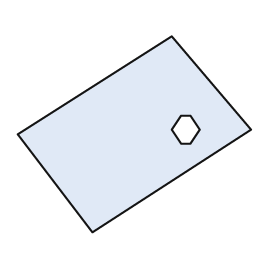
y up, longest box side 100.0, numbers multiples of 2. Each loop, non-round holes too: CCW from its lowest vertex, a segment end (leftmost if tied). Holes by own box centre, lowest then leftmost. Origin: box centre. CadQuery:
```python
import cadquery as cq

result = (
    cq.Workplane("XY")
    .moveTo(-18.0, -42.0)
    .lineTo(50.0, 2.0)
    .lineTo(16.0, 42.0)
    .lineTo(-50.0, 0.0)
    .close()
    .moveTo(20.0, -4.0)
    .lineTo(24.0, -4.0)
    .lineTo(28.0, 2.0)
    .lineTo(24.0, 8.0)
    .lineTo(20.0, 8.0)
    .lineTo(16.0, 2.0)
    .close()
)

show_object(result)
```